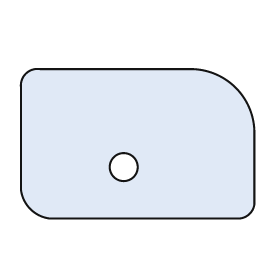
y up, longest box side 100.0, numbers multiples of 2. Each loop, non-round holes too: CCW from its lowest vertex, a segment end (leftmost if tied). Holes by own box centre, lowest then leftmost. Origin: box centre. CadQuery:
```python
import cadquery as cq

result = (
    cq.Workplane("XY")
    .moveTo(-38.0, -32.0)
    .lineTo(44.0, -32.0)
    .threePointArc((48.0, -30.0), (50.0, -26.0))
    .lineTo(50.0, 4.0)
    .threePointArc((42.0, 24.0), (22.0, 32.0))
    .lineTo(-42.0, 32.0)
    .threePointArc((-48.0, 30.0), (-50.0, 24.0))
    .lineTo(-50.0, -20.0)
    .threePointArc((-46.0, -28.0), (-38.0, -32.0))
    .close()
    .moveTo(-6.0, -10.0)
    .circle(6.0)
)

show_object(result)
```